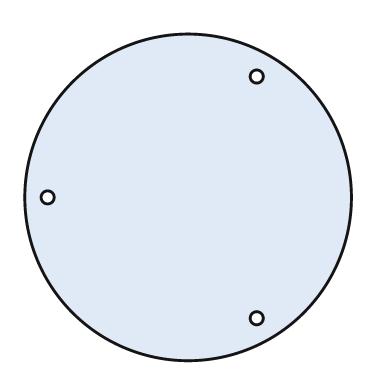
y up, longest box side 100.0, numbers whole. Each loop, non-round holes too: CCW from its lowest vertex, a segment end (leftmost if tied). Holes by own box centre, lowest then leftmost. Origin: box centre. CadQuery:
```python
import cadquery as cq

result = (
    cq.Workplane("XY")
    .moveTo(0.0, 0.0)
    .circle(50.0)
    .moveTo(21.0, -37.0)
    .circle(2.0)
    .moveTo(-43.0, 0.0)
    .circle(2.0)
    .moveTo(21.0, 37.0)
    .circle(2.0)
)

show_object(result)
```